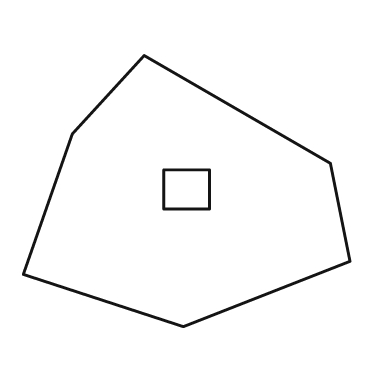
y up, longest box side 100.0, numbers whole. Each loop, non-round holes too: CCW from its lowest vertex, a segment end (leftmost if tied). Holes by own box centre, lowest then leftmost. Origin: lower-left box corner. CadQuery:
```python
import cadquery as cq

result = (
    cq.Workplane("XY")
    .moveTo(49.0, 0.0)
    .lineTo(100.0, 20.0)
    .lineTo(94.0, 50.0)
    .lineTo(37.0, 83.0)
    .lineTo(15.0, 59.0)
    .lineTo(0.0, 16.0)
    .close()
    .moveTo(43.0, 36.0)
    .lineTo(57.0, 36.0)
    .lineTo(57.0, 48.0)
    .lineTo(43.0, 48.0)
    .close()
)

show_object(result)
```